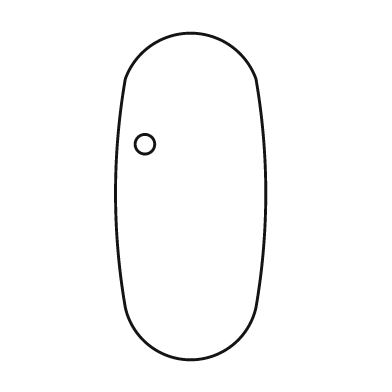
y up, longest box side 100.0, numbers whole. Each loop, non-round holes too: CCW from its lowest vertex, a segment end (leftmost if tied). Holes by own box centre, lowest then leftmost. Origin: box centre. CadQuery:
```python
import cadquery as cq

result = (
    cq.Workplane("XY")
    .moveTo(-20.0, -34.0)
    .threePointArc((0.0, -50.0), (20.0, -34.0))
    .threePointArc((23.0, 1.0), (20.0, 36.0))
    .threePointArc((0.0, 50.0), (-20.0, 36.0))
    .threePointArc((-23.0, 1.0), (-20.0, -34.0))
    .close()
    .moveTo(-14.0, 16.0)
    .circle(3.0)
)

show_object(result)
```